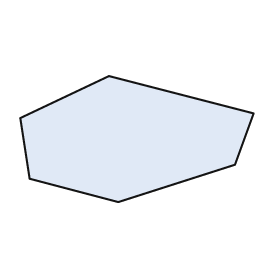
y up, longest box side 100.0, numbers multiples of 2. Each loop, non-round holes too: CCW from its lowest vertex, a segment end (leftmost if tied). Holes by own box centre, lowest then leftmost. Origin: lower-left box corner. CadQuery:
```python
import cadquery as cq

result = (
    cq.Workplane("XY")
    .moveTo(42.0, 0.0)
    .lineTo(92.0, 16.0)
    .lineTo(100.0, 38.0)
    .lineTo(38.0, 54.0)
    .lineTo(0.0, 36.0)
    .lineTo(4.0, 10.0)
    .close()
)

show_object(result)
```